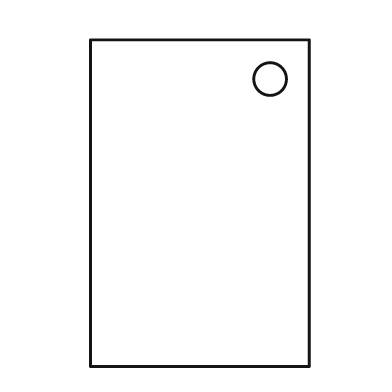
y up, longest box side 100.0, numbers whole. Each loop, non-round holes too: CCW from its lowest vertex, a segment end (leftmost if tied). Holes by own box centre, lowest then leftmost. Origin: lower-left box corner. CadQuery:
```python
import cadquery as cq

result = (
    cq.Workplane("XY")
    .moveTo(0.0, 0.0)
    .lineTo(67.0, 0.0)
    .lineTo(67.0, 100.0)
    .lineTo(0.0, 100.0)
    .close()
    .moveTo(55.0, 88.0)
    .circle(5.0)
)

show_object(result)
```